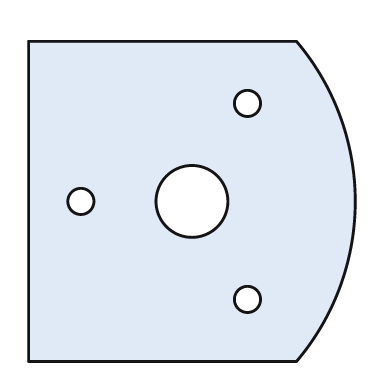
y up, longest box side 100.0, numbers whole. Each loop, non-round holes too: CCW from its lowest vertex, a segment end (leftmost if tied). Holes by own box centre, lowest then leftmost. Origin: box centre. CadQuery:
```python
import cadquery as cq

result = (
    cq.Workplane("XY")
    .moveTo(-50.0, -49.0)
    .lineTo(32.0, -49.0)
    .threePointArc((50.0, 0.0), (32.0, 49.0))
    .lineTo(-50.0, 49.0)
    .close()
    .moveTo(17.0, -30.0)
    .circle(4.0)
    .moveTo(-34.0, 0.0)
    .circle(4.0)
    .moveTo(0.0, 0.0)
    .circle(11.0)
    .moveTo(17.0, 30.0)
    .circle(4.0)
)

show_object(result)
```